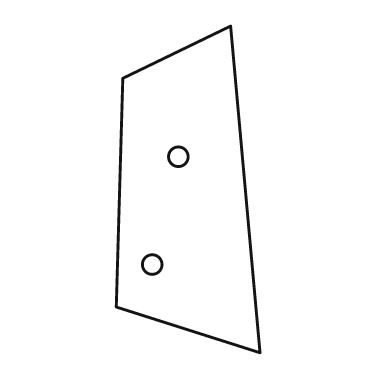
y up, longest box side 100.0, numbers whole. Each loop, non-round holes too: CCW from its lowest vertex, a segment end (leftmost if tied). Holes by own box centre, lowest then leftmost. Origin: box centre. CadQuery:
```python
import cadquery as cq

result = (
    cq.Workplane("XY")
    .moveTo(22.0, -50.0)
    .lineTo(13.0, 50.0)
    .lineTo(-20.0, 34.0)
    .lineTo(-22.0, -36.0)
    .close()
    .moveTo(-11.0, -23.0)
    .circle(3.0)
    .moveTo(-3.0, 10.0)
    .circle(3.0)
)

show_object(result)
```